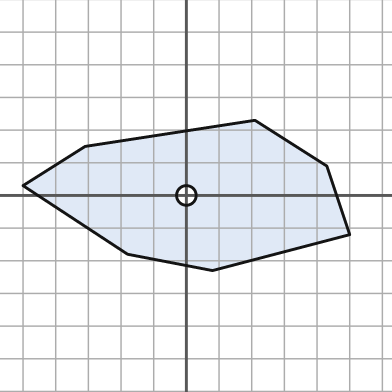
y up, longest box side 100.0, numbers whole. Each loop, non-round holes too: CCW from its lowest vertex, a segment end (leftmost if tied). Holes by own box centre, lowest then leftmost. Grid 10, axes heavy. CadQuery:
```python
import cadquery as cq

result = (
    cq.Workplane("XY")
    .moveTo(8.0, -23.0)
    .lineTo(50.0, -12.0)
    .lineTo(43.0, 9.0)
    .lineTo(21.0, 23.0)
    .lineTo(-31.0, 15.0)
    .lineTo(-50.0, 3.0)
    .lineTo(-18.0, -18.0)
    .close()
    .moveTo(0.0, 0.0)
    .circle(3.0)
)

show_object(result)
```